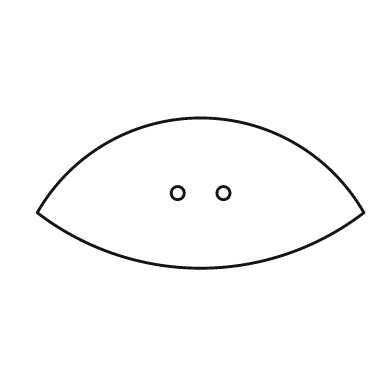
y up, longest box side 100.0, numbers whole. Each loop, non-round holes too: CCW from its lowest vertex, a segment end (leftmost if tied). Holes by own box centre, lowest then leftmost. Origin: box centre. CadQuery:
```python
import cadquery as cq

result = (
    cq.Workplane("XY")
    .moveTo(-50.0, -6.0)
    .threePointArc((0.0, -23.0), (50.0, -6.0))
    .threePointArc((0.0, 23.0), (-50.0, -6.0))
    .close()
    .moveTo(-7.0, 0.0)
    .circle(2.0)
    .moveTo(7.0, 0.0)
    .circle(2.0)
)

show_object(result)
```